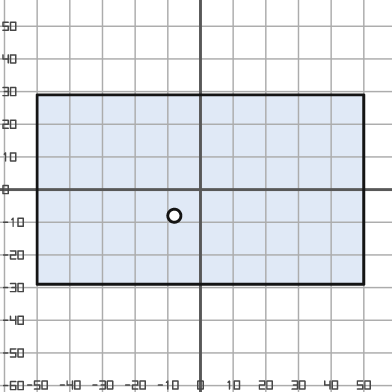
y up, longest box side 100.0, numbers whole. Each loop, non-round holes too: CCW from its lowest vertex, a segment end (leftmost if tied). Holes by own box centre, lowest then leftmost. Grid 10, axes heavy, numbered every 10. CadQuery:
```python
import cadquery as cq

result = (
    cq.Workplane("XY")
    .moveTo(-50.0, -29.0)
    .lineTo(50.0, -29.0)
    .lineTo(50.0, 29.0)
    .lineTo(-50.0, 29.0)
    .close()
    .moveTo(-8.0, -8.0)
    .circle(2.0)
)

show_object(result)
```